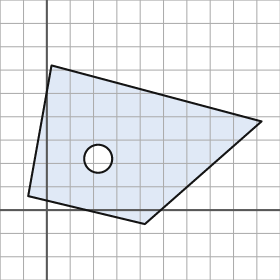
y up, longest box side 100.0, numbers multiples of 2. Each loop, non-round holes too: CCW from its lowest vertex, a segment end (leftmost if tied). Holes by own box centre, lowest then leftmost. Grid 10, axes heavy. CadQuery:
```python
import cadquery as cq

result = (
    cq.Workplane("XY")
    .moveTo(42.0, -6.0)
    .lineTo(92.0, 38.0)
    .lineTo(2.0, 62.0)
    .lineTo(-8.0, 6.0)
    .close()
    .moveTo(22.0, 22.0)
    .circle(6.0)
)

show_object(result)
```